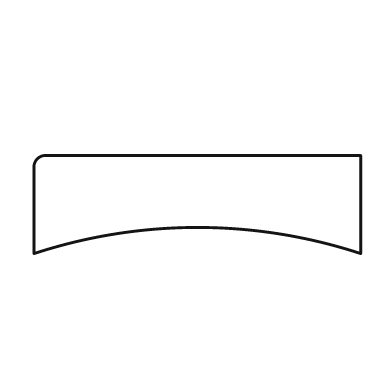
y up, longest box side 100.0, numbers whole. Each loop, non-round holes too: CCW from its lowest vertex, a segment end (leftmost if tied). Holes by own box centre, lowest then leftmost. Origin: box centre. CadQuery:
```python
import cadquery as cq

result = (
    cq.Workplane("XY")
    .moveTo(-50.0, -15.0)
    .threePointArc((0.0, -7.0), (50.0, -15.0))
    .lineTo(50.0, 15.0)
    .lineTo(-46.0, 15.0)
    .threePointArc((-49.0, 14.0), (-50.0, 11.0))
    .close()
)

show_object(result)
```